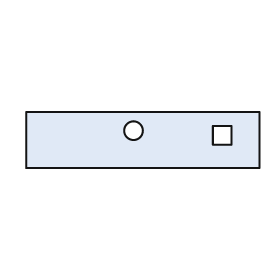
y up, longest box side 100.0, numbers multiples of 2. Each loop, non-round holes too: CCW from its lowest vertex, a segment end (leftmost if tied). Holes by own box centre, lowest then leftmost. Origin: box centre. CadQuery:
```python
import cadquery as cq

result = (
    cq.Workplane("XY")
    .moveTo(-50.0, -12.0)
    .lineTo(50.0, -12.0)
    .lineTo(50.0, 12.0)
    .lineTo(-50.0, 12.0)
    .close()
    .moveTo(30.0, -2.0)
    .lineTo(38.0, -2.0)
    .lineTo(38.0, 6.0)
    .lineTo(30.0, 6.0)
    .close()
    .moveTo(-4.0, 4.0)
    .circle(4.0)
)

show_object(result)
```